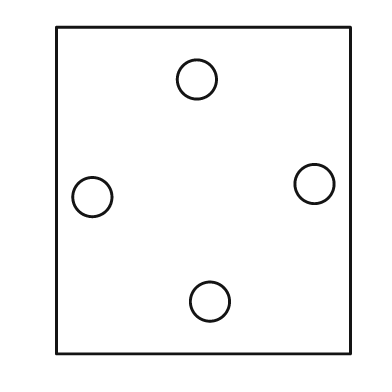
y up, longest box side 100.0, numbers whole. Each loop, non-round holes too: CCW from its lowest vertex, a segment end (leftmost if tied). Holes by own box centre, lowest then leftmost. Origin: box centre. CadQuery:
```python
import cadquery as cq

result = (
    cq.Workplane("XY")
    .moveTo(-45.0, -50.0)
    .lineTo(45.0, -50.0)
    .lineTo(45.0, 50.0)
    .lineTo(-45.0, 50.0)
    .close()
    .moveTo(2.0, -34.0)
    .circle(6.0)
    .moveTo(-34.0, -2.0)
    .circle(6.0)
    .moveTo(34.0, 2.0)
    .circle(6.0)
    .moveTo(-2.0, 34.0)
    .circle(6.0)
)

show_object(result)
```